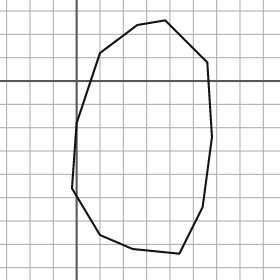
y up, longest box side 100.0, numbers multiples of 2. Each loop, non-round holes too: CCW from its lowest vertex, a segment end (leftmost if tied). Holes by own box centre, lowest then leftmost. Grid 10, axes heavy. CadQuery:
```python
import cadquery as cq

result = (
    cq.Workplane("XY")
    .moveTo(44.0, -74.0)
    .lineTo(54.0, -54.0)
    .lineTo(58.0, -24.0)
    .lineTo(56.0, 8.0)
    .lineTo(38.0, 26.0)
    .lineTo(26.0, 24.0)
    .lineTo(10.0, 12.0)
    .lineTo(0.0, -18.0)
    .lineTo(-2.0, -46.0)
    .lineTo(10.0, -66.0)
    .lineTo(24.0, -72.0)
    .close()
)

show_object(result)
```